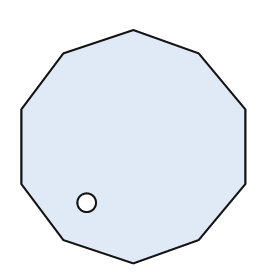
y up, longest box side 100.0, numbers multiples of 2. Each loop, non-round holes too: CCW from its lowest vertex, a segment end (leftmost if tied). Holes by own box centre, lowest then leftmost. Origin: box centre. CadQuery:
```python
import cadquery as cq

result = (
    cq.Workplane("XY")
    .moveTo(0.0, -50.0)
    .lineTo(28.0, -40.0)
    .lineTo(48.0, -16.0)
    .lineTo(48.0, 16.0)
    .lineTo(28.0, 40.0)
    .lineTo(0.0, 50.0)
    .lineTo(-30.0, 40.0)
    .lineTo(-48.0, 16.0)
    .lineTo(-48.0, -16.0)
    .lineTo(-30.0, -40.0)
    .close()
    .moveTo(-20.0, -24.0)
    .circle(4.0)
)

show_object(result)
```